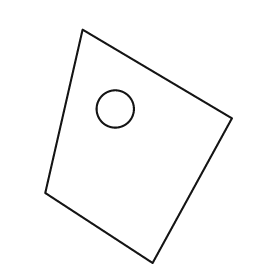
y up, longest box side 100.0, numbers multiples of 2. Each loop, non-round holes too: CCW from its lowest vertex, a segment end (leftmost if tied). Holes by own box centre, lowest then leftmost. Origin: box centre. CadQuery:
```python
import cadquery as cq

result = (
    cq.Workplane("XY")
    .moveTo(6.0, -50.0)
    .lineTo(40.0, 12.0)
    .lineTo(-24.0, 50.0)
    .lineTo(-40.0, -20.0)
    .close()
    .moveTo(-10.0, 16.0)
    .circle(8.0)
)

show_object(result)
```